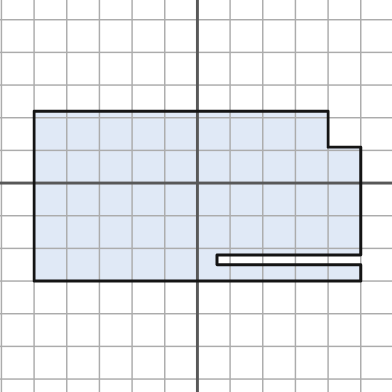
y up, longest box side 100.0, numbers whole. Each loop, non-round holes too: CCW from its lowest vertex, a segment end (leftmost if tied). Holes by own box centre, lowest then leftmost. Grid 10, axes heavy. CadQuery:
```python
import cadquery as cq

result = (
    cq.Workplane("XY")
    .moveTo(-50.0, -30.0)
    .lineTo(50.0, -30.0)
    .lineTo(50.0, -25.0)
    .lineTo(6.0, -25.0)
    .lineTo(6.0, -22.0)
    .lineTo(50.0, -22.0)
    .lineTo(50.0, 11.0)
    .lineTo(40.0, 11.0)
    .lineTo(40.0, 22.0)
    .lineTo(-50.0, 22.0)
    .close()
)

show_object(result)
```